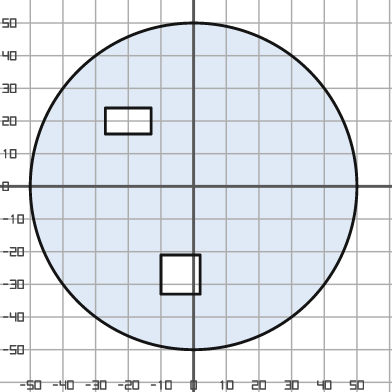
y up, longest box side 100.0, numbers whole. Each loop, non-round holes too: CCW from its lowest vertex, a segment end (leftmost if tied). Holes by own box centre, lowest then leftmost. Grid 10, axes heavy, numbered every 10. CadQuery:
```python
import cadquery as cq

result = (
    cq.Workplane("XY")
    .moveTo(0.0, 0.0)
    .circle(50.0)
    .moveTo(-10.0, -33.0)
    .lineTo(2.0, -33.0)
    .lineTo(2.0, -21.0)
    .lineTo(-10.0, -21.0)
    .close()
    .moveTo(-27.0, 16.0)
    .lineTo(-13.0, 16.0)
    .lineTo(-13.0, 24.0)
    .lineTo(-27.0, 24.0)
    .close()
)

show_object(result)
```